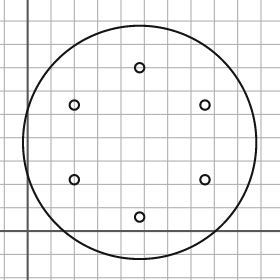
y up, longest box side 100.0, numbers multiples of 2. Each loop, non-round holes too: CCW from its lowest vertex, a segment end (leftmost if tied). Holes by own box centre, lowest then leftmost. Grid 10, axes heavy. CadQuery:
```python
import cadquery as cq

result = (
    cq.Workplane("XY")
    .moveTo(48.0, 38.0)
    .circle(50.0)
    .moveTo(48.0, 6.0)
    .circle(2.0)
    .moveTo(20.0, 22.0)
    .circle(2.0)
    .moveTo(76.0, 22.0)
    .circle(2.0)
    .moveTo(20.0, 54.0)
    .circle(2.0)
    .moveTo(76.0, 54.0)
    .circle(2.0)
    .moveTo(48.0, 70.0)
    .circle(2.0)
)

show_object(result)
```